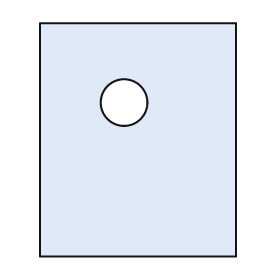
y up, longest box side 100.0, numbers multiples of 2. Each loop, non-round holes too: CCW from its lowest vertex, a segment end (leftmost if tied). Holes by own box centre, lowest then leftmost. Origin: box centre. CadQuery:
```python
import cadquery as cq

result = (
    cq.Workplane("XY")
    .moveTo(-42.0, -50.0)
    .lineTo(42.0, -50.0)
    .lineTo(42.0, 50.0)
    .lineTo(-42.0, 50.0)
    .close()
    .moveTo(-6.0, 16.0)
    .circle(10.0)
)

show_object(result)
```